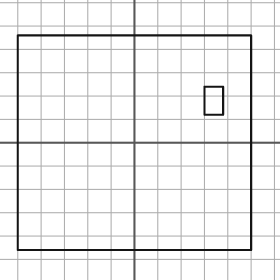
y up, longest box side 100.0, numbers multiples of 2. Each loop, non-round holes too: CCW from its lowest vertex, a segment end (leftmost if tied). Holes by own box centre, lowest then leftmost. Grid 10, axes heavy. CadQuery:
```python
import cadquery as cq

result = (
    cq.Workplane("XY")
    .moveTo(-50.0, -46.0)
    .lineTo(50.0, -46.0)
    .lineTo(50.0, 46.0)
    .lineTo(-50.0, 46.0)
    .close()
    .moveTo(30.0, 12.0)
    .lineTo(38.0, 12.0)
    .lineTo(38.0, 24.0)
    .lineTo(30.0, 24.0)
    .close()
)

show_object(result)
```